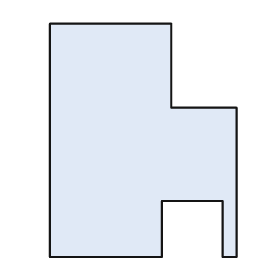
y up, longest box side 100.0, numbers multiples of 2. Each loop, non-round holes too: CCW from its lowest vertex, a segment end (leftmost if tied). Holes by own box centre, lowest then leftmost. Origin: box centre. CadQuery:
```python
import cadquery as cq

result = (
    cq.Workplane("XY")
    .moveTo(-40.0, -50.0)
    .lineTo(8.0, -50.0)
    .lineTo(8.0, -26.0)
    .lineTo(34.0, -26.0)
    .lineTo(34.0, -50.0)
    .lineTo(40.0, -50.0)
    .lineTo(40.0, 14.0)
    .lineTo(12.0, 14.0)
    .lineTo(12.0, 50.0)
    .lineTo(-40.0, 50.0)
    .close()
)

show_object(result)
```